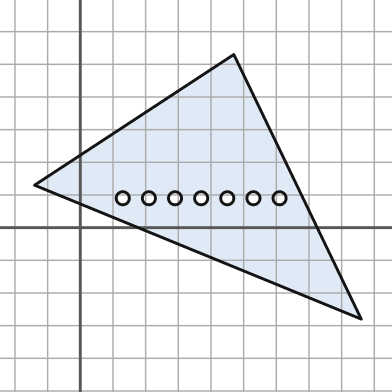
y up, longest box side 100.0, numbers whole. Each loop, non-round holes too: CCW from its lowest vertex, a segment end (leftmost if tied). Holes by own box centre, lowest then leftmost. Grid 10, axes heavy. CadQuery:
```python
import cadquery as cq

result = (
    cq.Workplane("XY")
    .moveTo(86.0, -28.0)
    .lineTo(47.0, 53.0)
    .lineTo(-14.0, 13.0)
    .close()
    .moveTo(13.0, 9.0)
    .circle(2.0)
    .moveTo(21.0, 9.0)
    .circle(2.0)
    .moveTo(29.0, 9.0)
    .circle(2.0)
    .moveTo(37.0, 9.0)
    .circle(2.0)
    .moveTo(45.0, 9.0)
    .circle(2.0)
    .moveTo(53.0, 9.0)
    .circle(2.0)
    .moveTo(61.0, 9.0)
    .circle(2.0)
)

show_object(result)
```